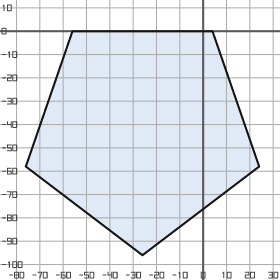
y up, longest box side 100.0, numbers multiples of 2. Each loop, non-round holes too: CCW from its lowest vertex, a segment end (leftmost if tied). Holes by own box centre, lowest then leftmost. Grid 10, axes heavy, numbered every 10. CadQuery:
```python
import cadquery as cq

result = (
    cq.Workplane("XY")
    .moveTo(-26.0, -96.0)
    .lineTo(24.0, -58.0)
    .lineTo(4.0, 0.0)
    .lineTo(-56.0, 0.0)
    .lineTo(-76.0, -58.0)
    .close()
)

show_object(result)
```